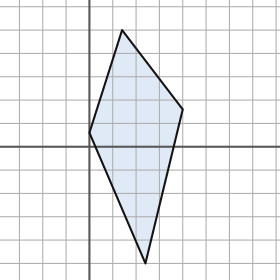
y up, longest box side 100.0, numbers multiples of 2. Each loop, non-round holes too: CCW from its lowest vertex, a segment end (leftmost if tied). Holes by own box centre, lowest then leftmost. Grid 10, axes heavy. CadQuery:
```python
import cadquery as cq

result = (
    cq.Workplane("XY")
    .moveTo(24.0, -50.0)
    .lineTo(40.0, 16.0)
    .lineTo(14.0, 50.0)
    .lineTo(0.0, 6.0)
    .close()
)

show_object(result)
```